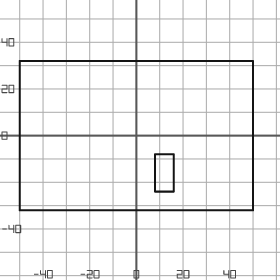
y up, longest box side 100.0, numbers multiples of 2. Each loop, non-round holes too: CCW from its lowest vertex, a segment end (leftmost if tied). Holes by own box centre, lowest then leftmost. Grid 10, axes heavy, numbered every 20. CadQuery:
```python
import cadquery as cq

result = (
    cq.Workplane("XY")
    .moveTo(-50.0, -32.0)
    .lineTo(50.0, -32.0)
    .lineTo(50.0, 32.0)
    .lineTo(-50.0, 32.0)
    .close()
    .moveTo(8.0, -24.0)
    .lineTo(16.0, -24.0)
    .lineTo(16.0, -8.0)
    .lineTo(8.0, -8.0)
    .close()
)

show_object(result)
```